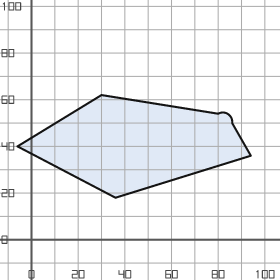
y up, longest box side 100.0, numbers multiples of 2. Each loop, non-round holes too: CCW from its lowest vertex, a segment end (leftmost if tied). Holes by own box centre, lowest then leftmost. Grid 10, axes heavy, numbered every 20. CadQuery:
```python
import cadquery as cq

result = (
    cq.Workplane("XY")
    .moveTo(36.0, 18.0)
    .lineTo(94.0, 36.0)
    .lineTo(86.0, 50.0)
    .threePointArc((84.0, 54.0), (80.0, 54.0))
    .lineTo(30.0, 62.0)
    .lineTo(-6.0, 40.0)
    .close()
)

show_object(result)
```